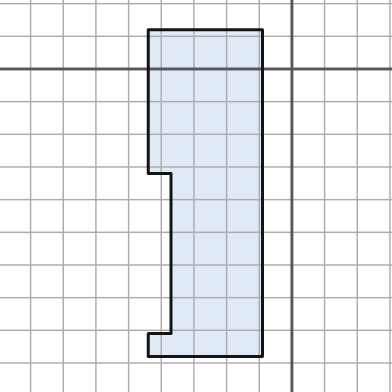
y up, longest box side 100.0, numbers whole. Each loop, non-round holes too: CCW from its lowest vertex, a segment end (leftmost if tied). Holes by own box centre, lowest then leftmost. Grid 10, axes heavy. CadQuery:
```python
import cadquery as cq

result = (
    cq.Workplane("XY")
    .moveTo(-44.0, -88.0)
    .lineTo(-9.0, -88.0)
    .lineTo(-9.0, 12.0)
    .lineTo(-44.0, 12.0)
    .lineTo(-44.0, -32.0)
    .lineTo(-37.0, -32.0)
    .lineTo(-37.0, -81.0)
    .lineTo(-44.0, -81.0)
    .close()
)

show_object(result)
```